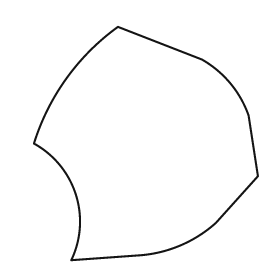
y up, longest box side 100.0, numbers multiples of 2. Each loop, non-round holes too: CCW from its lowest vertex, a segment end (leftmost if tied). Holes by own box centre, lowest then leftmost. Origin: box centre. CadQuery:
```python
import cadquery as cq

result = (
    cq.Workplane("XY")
    .moveTo(-32.0, -50.0)
    .lineTo(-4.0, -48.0)
    .threePointArc((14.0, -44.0), (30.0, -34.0))
    .lineTo(48.0, -14.0)
    .lineTo(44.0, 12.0)
    .threePointArc((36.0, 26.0), (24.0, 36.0))
    .lineTo(-12.0, 50.0)
    .threePointArc((-34.0, 28.0), (-48.0, 0.0))
    .threePointArc((-30.0, -22.0), (-32.0, -50.0))
    .close()
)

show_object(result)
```